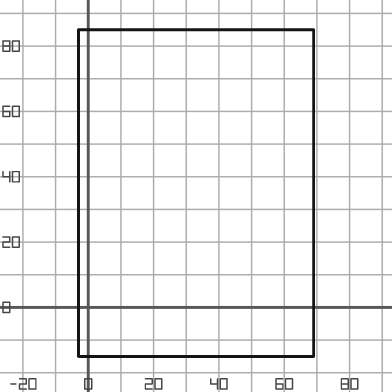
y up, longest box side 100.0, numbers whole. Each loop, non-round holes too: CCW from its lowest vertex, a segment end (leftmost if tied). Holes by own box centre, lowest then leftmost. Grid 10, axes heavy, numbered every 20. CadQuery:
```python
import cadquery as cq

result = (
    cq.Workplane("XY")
    .moveTo(-3.0, -15.0)
    .lineTo(69.0, -15.0)
    .lineTo(69.0, 85.0)
    .lineTo(-3.0, 85.0)
    .close()
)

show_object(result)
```